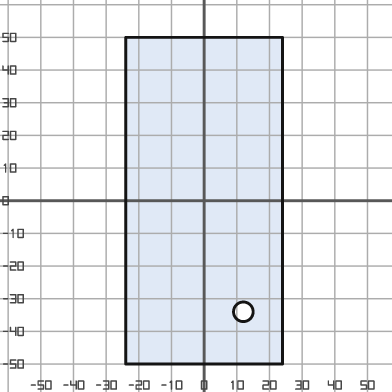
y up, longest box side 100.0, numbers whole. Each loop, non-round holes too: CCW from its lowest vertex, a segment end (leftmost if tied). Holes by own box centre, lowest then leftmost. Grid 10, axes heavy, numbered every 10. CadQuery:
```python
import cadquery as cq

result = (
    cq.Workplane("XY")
    .moveTo(-24.0, -50.0)
    .lineTo(24.0, -50.0)
    .lineTo(24.0, 50.0)
    .lineTo(-24.0, 50.0)
    .close()
    .moveTo(12.0, -34.0)
    .circle(3.0)
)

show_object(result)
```